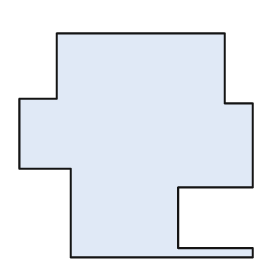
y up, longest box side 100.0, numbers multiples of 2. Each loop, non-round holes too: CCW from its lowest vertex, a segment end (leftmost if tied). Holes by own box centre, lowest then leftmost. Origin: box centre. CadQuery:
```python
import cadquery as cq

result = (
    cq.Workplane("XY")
    .moveTo(-28.0, -48.0)
    .lineTo(50.0, -48.0)
    .lineTo(50.0, -44.0)
    .lineTo(18.0, -44.0)
    .lineTo(18.0, -18.0)
    .lineTo(50.0, -18.0)
    .lineTo(50.0, 18.0)
    .lineTo(38.0, 18.0)
    .lineTo(38.0, 48.0)
    .lineTo(-34.0, 48.0)
    .lineTo(-34.0, 20.0)
    .lineTo(-50.0, 20.0)
    .lineTo(-50.0, -10.0)
    .lineTo(-28.0, -10.0)
    .close()
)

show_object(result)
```